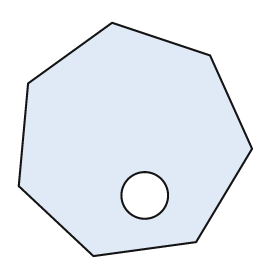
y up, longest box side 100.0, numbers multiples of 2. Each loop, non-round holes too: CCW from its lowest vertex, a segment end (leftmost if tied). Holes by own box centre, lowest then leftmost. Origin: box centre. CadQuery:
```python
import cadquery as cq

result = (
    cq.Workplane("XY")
    .moveTo(-18.0, -50.0)
    .lineTo(26.0, -44.0)
    .lineTo(50.0, -4.0)
    .lineTo(32.0, 36.0)
    .lineTo(-10.0, 50.0)
    .lineTo(-46.0, 24.0)
    .lineTo(-50.0, -20.0)
    .close()
    .moveTo(4.0, -24.0)
    .circle(10.0)
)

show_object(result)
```